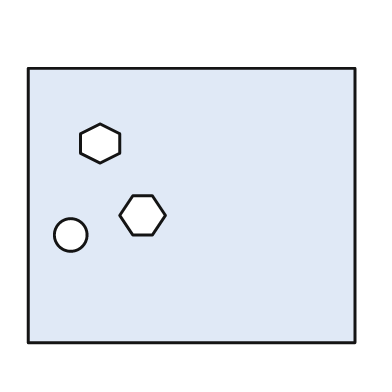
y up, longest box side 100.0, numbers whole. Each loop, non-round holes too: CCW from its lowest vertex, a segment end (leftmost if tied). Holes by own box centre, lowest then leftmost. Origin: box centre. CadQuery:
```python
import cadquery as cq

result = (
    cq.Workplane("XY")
    .moveTo(-50.0, -42.0)
    .lineTo(50.0, -42.0)
    .lineTo(50.0, 42.0)
    .lineTo(-50.0, 42.0)
    .close()
    .moveTo(-37.0, -9.0)
    .circle(5.0)
    .moveTo(-18.0, -9.0)
    .lineTo(-12.0, -9.0)
    .lineTo(-8.0, -3.0)
    .lineTo(-12.0, 3.0)
    .lineTo(-18.0, 3.0)
    .lineTo(-22.0, -3.0)
    .close()
    .moveTo(-28.0, 13.0)
    .lineTo(-22.0, 16.0)
    .lineTo(-22.0, 22.0)
    .lineTo(-28.0, 25.0)
    .lineTo(-34.0, 22.0)
    .lineTo(-34.0, 16.0)
    .close()
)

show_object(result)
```